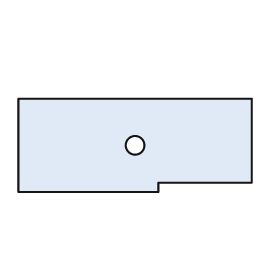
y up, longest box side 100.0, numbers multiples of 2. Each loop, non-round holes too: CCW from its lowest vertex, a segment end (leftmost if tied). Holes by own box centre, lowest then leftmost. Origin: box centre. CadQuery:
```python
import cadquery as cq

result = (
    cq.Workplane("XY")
    .moveTo(-50.0, -20.0)
    .lineTo(10.0, -20.0)
    .lineTo(10.0, -16.0)
    .lineTo(50.0, -16.0)
    .lineTo(50.0, 20.0)
    .lineTo(-50.0, 20.0)
    .close()
    .moveTo(0.0, 0.0)
    .circle(4.0)
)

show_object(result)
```